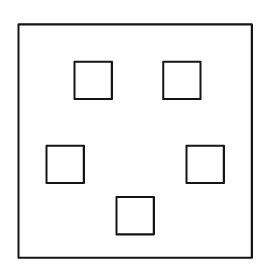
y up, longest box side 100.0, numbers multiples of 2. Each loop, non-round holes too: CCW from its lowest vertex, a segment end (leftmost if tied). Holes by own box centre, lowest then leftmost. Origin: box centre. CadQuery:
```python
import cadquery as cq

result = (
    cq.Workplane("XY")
    .moveTo(-50.0, -50.0)
    .lineTo(50.0, -50.0)
    .lineTo(50.0, 50.0)
    .lineTo(-50.0, 50.0)
    .close()
    .moveTo(-8.0, -40.0)
    .lineTo(8.0, -40.0)
    .lineTo(8.0, -24.0)
    .lineTo(-8.0, -24.0)
    .close()
    .moveTo(-38.0, -18.0)
    .lineTo(-22.0, -18.0)
    .lineTo(-22.0, -2.0)
    .lineTo(-38.0, -2.0)
    .close()
    .moveTo(22.0, -18.0)
    .lineTo(38.0, -18.0)
    .lineTo(38.0, -2.0)
    .lineTo(22.0, -2.0)
    .close()
    .moveTo(-26.0, 18.0)
    .lineTo(-10.0, 18.0)
    .lineTo(-10.0, 34.0)
    .lineTo(-26.0, 34.0)
    .close()
    .moveTo(12.0, 18.0)
    .lineTo(28.0, 18.0)
    .lineTo(28.0, 34.0)
    .lineTo(12.0, 34.0)
    .close()
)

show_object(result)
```